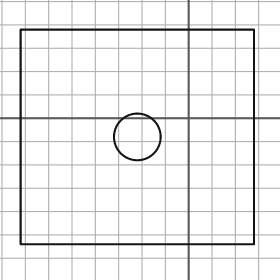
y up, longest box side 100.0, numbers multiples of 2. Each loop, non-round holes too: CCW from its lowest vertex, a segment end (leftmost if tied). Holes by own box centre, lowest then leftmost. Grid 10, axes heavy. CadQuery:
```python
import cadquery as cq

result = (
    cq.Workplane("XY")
    .moveTo(-72.0, -54.0)
    .lineTo(28.0, -54.0)
    .lineTo(28.0, 38.0)
    .lineTo(-72.0, 38.0)
    .close()
    .moveTo(-22.0, -8.0)
    .circle(10.0)
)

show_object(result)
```